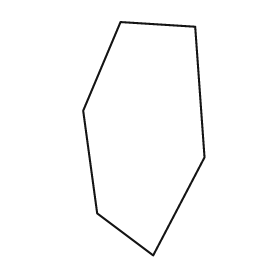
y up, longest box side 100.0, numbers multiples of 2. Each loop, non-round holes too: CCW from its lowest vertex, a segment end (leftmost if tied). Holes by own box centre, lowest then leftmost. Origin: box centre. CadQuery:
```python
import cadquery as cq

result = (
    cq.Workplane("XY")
    .moveTo(4.0, -50.0)
    .lineTo(26.0, -8.0)
    .lineTo(22.0, 48.0)
    .lineTo(-10.0, 50.0)
    .lineTo(-26.0, 12.0)
    .lineTo(-20.0, -32.0)
    .close()
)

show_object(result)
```